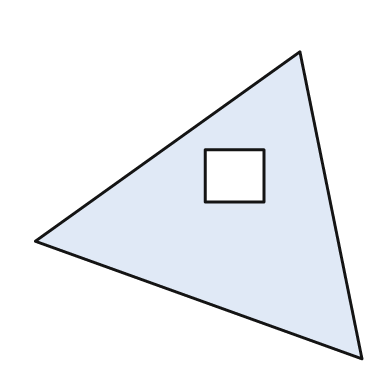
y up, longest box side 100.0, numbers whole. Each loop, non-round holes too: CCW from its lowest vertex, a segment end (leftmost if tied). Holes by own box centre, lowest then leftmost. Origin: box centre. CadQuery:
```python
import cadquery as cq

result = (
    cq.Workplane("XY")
    .moveTo(50.0, -47.0)
    .lineTo(31.0, 47.0)
    .lineTo(-50.0, -11.0)
    .close()
    .moveTo(2.0, 1.0)
    .lineTo(20.0, 1.0)
    .lineTo(20.0, 17.0)
    .lineTo(2.0, 17.0)
    .close()
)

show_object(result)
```